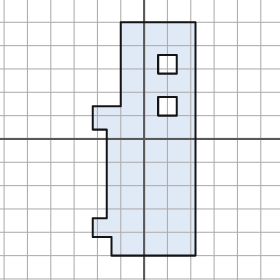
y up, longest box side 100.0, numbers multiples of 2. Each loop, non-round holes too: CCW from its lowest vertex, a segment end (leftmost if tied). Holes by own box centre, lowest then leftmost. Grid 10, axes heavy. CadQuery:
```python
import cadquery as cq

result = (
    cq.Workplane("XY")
    .moveTo(-14.0, -50.0)
    .lineTo(22.0, -50.0)
    .lineTo(22.0, 50.0)
    .lineTo(-10.0, 50.0)
    .lineTo(-10.0, 14.0)
    .lineTo(-22.0, 14.0)
    .lineTo(-22.0, 4.0)
    .lineTo(-16.0, 4.0)
    .lineTo(-16.0, -34.0)
    .lineTo(-22.0, -34.0)
    .lineTo(-22.0, -42.0)
    .lineTo(-14.0, -42.0)
    .close()
    .moveTo(6.0, 10.0)
    .lineTo(14.0, 10.0)
    .lineTo(14.0, 18.0)
    .lineTo(6.0, 18.0)
    .close()
    .moveTo(6.0, 28.0)
    .lineTo(14.0, 28.0)
    .lineTo(14.0, 36.0)
    .lineTo(6.0, 36.0)
    .close()
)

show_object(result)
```